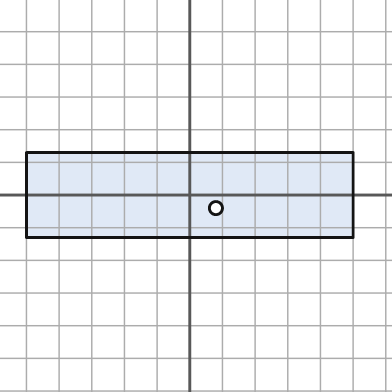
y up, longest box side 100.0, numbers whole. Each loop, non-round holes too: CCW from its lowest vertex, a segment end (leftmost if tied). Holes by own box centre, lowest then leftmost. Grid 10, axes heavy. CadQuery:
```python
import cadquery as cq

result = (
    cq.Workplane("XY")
    .moveTo(-50.0, -13.0)
    .lineTo(50.0, -13.0)
    .lineTo(50.0, 13.0)
    .lineTo(-50.0, 13.0)
    .close()
    .moveTo(8.0, -4.0)
    .circle(2.0)
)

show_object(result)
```